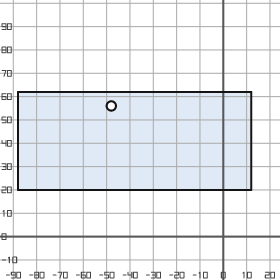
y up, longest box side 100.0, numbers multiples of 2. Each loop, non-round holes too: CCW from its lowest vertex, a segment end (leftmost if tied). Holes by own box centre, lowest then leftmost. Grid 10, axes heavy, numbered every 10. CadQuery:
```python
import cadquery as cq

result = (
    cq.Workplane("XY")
    .moveTo(-88.0, 20.0)
    .lineTo(12.0, 20.0)
    .lineTo(12.0, 62.0)
    .lineTo(-88.0, 62.0)
    .close()
    .moveTo(-48.0, 56.0)
    .circle(2.0)
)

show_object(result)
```